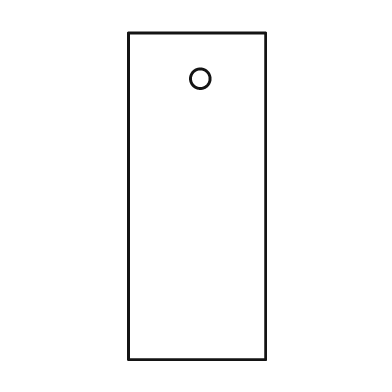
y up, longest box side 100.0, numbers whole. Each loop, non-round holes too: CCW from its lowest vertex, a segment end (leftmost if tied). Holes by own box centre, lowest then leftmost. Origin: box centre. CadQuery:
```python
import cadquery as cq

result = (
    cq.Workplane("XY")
    .moveTo(-21.0, -50.0)
    .lineTo(21.0, -50.0)
    .lineTo(21.0, 50.0)
    .lineTo(-21.0, 50.0)
    .close()
    .moveTo(1.0, 36.0)
    .circle(3.0)
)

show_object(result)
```